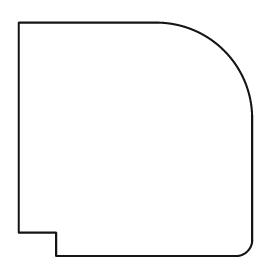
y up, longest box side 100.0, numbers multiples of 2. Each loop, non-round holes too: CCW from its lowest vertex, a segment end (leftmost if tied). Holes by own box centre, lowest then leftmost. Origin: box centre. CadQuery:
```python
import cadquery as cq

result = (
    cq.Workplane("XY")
    .moveTo(-34.0, -50.0)
    .lineTo(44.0, -50.0)
    .threePointArc((48.0, -48.0), (50.0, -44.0))
    .lineTo(50.0, 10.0)
    .threePointArc((38.0, 38.0), (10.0, 50.0))
    .lineTo(-50.0, 50.0)
    .lineTo(-50.0, -40.0)
    .lineTo(-34.0, -40.0)
    .close()
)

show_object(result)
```